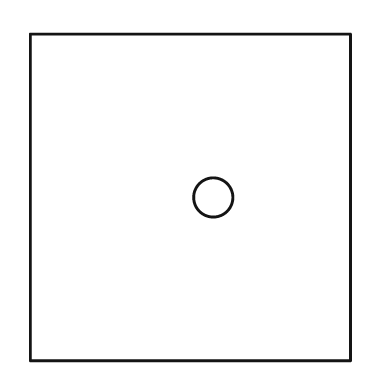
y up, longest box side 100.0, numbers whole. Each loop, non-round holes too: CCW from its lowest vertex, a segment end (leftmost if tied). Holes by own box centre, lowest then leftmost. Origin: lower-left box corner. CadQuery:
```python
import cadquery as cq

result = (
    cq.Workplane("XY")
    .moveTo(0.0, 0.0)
    .lineTo(98.0, 0.0)
    .lineTo(98.0, 100.0)
    .lineTo(0.0, 100.0)
    .close()
    .moveTo(56.0, 50.0)
    .circle(6.0)
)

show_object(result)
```